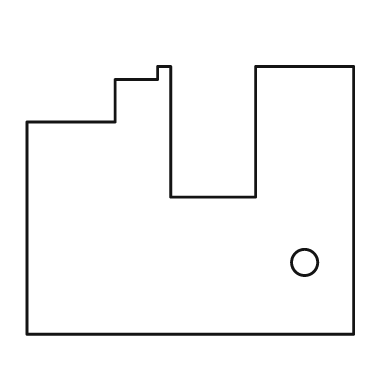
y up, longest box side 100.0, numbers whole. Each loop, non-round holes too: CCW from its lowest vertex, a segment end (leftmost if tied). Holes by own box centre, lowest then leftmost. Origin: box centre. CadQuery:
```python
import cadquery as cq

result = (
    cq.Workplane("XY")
    .moveTo(-50.0, -41.0)
    .lineTo(50.0, -41.0)
    .lineTo(50.0, 41.0)
    .lineTo(20.0, 41.0)
    .lineTo(20.0, 1.0)
    .lineTo(-6.0, 1.0)
    .lineTo(-6.0, 41.0)
    .lineTo(-10.0, 41.0)
    .lineTo(-10.0, 37.0)
    .lineTo(-23.0, 37.0)
    .lineTo(-23.0, 24.0)
    .lineTo(-50.0, 24.0)
    .close()
    .moveTo(35.0, -19.0)
    .circle(4.0)
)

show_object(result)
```